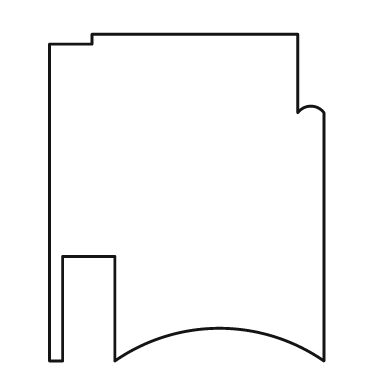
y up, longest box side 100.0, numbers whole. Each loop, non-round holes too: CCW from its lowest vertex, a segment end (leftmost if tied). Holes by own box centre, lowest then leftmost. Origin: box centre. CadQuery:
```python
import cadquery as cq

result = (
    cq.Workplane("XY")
    .moveTo(-42.0, -50.0)
    .lineTo(-38.0, -50.0)
    .lineTo(-38.0, -18.0)
    .lineTo(-22.0, -18.0)
    .lineTo(-22.0, -50.0)
    .threePointArc((10.0, -40.0), (42.0, -50.0))
    .lineTo(42.0, 26.0)
    .threePointArc((38.0, 28.0), (34.0, 26.0))
    .lineTo(34.0, 50.0)
    .lineTo(-29.0, 50.0)
    .lineTo(-29.0, 47.0)
    .lineTo(-42.0, 47.0)
    .close()
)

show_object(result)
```